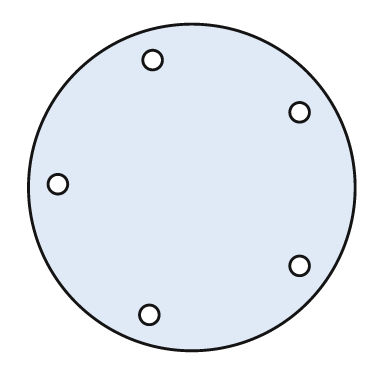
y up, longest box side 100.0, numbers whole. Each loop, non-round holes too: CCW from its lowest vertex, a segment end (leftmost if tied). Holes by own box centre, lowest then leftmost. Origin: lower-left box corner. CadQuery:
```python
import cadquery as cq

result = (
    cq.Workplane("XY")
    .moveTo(50.0, 50.0)
    .circle(50.0)
    .moveTo(37.0, 11.0)
    .circle(3.0)
    .moveTo(83.0, 26.0)
    .circle(3.0)
    .moveTo(9.0, 51.0)
    .circle(3.0)
    .moveTo(83.0, 73.0)
    .circle(3.0)
    .moveTo(38.0, 89.0)
    .circle(3.0)
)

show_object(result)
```